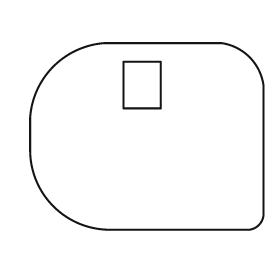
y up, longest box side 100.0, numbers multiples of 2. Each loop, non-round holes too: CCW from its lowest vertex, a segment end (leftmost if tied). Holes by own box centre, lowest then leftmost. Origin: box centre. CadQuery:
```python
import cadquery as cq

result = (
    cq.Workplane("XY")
    .moveTo(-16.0, -40.0)
    .lineTo(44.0, -40.0)
    .threePointArc((48.0, -38.0), (50.0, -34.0))
    .lineTo(50.0, 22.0)
    .threePointArc((44.0, 34.0), (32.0, 40.0))
    .lineTo(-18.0, 40.0)
    .threePointArc((-40.0, 30.0), (-50.0, 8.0))
    .lineTo(-50.0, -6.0)
    .threePointArc((-40.0, -30.0), (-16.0, -40.0))
    .close()
    .moveTo(-10.0, 12.0)
    .lineTo(6.0, 12.0)
    .lineTo(6.0, 32.0)
    .lineTo(-10.0, 32.0)
    .close()
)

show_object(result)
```